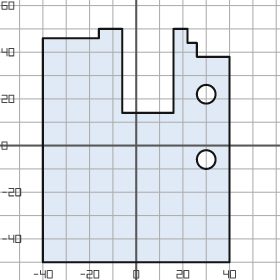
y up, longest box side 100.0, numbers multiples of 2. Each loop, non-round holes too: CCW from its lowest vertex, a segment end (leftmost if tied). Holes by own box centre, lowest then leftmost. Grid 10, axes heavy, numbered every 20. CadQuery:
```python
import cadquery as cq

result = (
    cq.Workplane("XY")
    .moveTo(-40.0, -50.0)
    .lineTo(40.0, -50.0)
    .lineTo(40.0, 38.0)
    .lineTo(26.0, 38.0)
    .lineTo(26.0, 44.0)
    .lineTo(22.0, 44.0)
    .lineTo(22.0, 50.0)
    .lineTo(16.0, 50.0)
    .lineTo(16.0, 14.0)
    .lineTo(-6.0, 14.0)
    .lineTo(-6.0, 50.0)
    .lineTo(-16.0, 50.0)
    .lineTo(-16.0, 46.0)
    .lineTo(-40.0, 46.0)
    .close()
    .moveTo(30.0, -6.0)
    .circle(4.0)
    .moveTo(30.0, 22.0)
    .circle(4.0)
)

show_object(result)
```